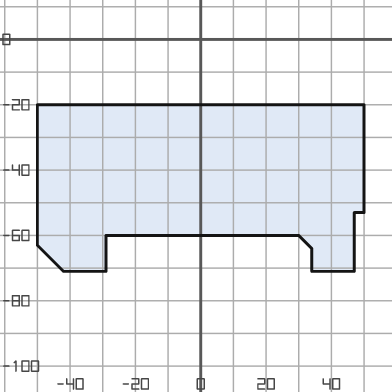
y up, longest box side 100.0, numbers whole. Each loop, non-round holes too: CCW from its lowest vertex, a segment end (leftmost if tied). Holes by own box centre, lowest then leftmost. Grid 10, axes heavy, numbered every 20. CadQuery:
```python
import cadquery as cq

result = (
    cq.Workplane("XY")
    .moveTo(-42.0, -71.0)
    .lineTo(-29.0, -71.0)
    .lineTo(-29.0, -60.0)
    .lineTo(30.0, -60.0)
    .lineTo(34.0, -64.0)
    .lineTo(34.0, -71.0)
    .lineTo(47.0, -71.0)
    .lineTo(47.0, -53.0)
    .lineTo(50.0, -53.0)
    .lineTo(50.0, -20.0)
    .lineTo(-50.0, -20.0)
    .lineTo(-50.0, -63.0)
    .close()
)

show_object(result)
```